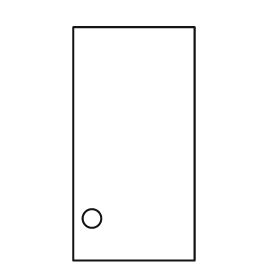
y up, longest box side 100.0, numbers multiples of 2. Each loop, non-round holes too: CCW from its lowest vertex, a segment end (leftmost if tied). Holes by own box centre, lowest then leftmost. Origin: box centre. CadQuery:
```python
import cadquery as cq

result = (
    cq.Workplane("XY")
    .moveTo(-26.0, -50.0)
    .lineTo(26.0, -50.0)
    .lineTo(26.0, 50.0)
    .lineTo(-26.0, 50.0)
    .close()
    .moveTo(-18.0, -32.0)
    .circle(4.0)
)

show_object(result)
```